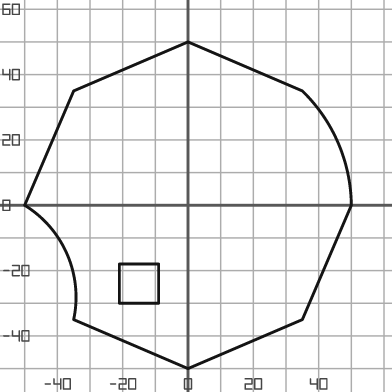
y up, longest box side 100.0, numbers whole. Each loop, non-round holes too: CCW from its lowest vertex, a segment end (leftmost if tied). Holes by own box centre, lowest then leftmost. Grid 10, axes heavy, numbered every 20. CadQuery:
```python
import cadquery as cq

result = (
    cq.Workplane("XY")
    .moveTo(0.0, -50.0)
    .lineTo(35.0, -35.0)
    .lineTo(50.0, 0.0)
    .threePointArc((46.0, 19.0), (35.0, 35.0))
    .lineTo(0.0, 50.0)
    .lineTo(-35.0, 35.0)
    .lineTo(-50.0, 0.0)
    .threePointArc((-37.0, -15.0), (-35.0, -35.0))
    .close()
    .moveTo(-21.0, -30.0)
    .lineTo(-9.0, -30.0)
    .lineTo(-9.0, -18.0)
    .lineTo(-21.0, -18.0)
    .close()
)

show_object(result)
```